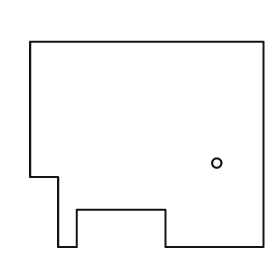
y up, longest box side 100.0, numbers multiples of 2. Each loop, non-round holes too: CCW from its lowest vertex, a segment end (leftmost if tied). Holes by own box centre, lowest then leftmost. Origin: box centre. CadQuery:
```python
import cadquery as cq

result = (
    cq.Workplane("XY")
    .moveTo(-38.0, -44.0)
    .lineTo(-30.0, -44.0)
    .lineTo(-30.0, -28.0)
    .lineTo(8.0, -28.0)
    .lineTo(8.0, -44.0)
    .lineTo(50.0, -44.0)
    .lineTo(50.0, 44.0)
    .lineTo(-50.0, 44.0)
    .lineTo(-50.0, -14.0)
    .lineTo(-38.0, -14.0)
    .close()
    .moveTo(30.0, -8.0)
    .circle(2.0)
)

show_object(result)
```